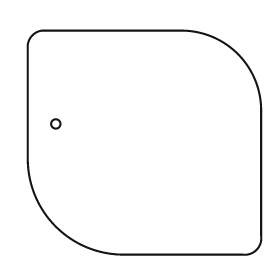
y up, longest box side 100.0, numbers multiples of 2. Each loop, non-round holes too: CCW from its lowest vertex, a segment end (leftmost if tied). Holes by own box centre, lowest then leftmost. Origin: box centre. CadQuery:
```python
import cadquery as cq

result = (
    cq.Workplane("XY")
    .moveTo(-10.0, -48.0)
    .lineTo(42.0, -48.0)
    .threePointArc((48.0, -46.0), (50.0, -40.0))
    .lineTo(50.0, 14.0)
    .threePointArc((40.0, 38.0), (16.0, 48.0))
    .lineTo(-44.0, 48.0)
    .threePointArc((-48.0, 46.0), (-50.0, 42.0))
    .lineTo(-50.0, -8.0)
    .threePointArc((-38.0, -36.0), (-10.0, -48.0))
    .close()
    .moveTo(-38.0, 8.0)
    .circle(2.0)
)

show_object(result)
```